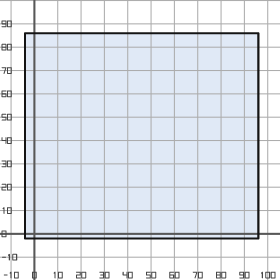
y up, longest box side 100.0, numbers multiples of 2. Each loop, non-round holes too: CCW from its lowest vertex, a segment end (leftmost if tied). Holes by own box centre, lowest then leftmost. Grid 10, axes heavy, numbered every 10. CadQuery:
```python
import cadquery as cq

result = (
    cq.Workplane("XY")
    .moveTo(-4.0, -2.0)
    .lineTo(96.0, -2.0)
    .lineTo(96.0, 86.0)
    .lineTo(-4.0, 86.0)
    .close()
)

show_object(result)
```